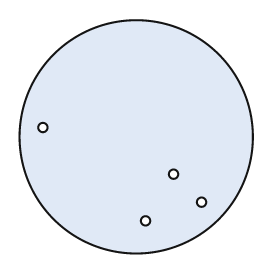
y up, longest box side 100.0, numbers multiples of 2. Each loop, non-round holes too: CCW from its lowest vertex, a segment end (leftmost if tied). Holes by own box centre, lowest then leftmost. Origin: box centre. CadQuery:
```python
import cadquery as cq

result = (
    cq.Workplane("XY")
    .moveTo(0.0, 0.0)
    .circle(50.0)
    .moveTo(4.0, -36.0)
    .circle(2.0)
    .moveTo(28.0, -28.0)
    .circle(2.0)
    .moveTo(16.0, -16.0)
    .circle(2.0)
    .moveTo(-40.0, 4.0)
    .circle(2.0)
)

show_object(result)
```